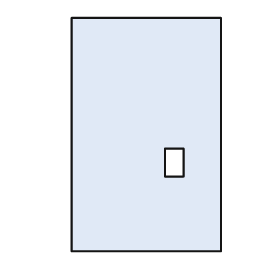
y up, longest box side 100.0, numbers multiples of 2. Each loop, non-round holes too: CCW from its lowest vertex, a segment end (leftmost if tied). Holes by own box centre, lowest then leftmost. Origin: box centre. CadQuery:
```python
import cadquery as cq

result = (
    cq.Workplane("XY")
    .moveTo(-32.0, -50.0)
    .lineTo(32.0, -50.0)
    .lineTo(32.0, 50.0)
    .lineTo(-32.0, 50.0)
    .close()
    .moveTo(8.0, -18.0)
    .lineTo(16.0, -18.0)
    .lineTo(16.0, -6.0)
    .lineTo(8.0, -6.0)
    .close()
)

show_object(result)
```